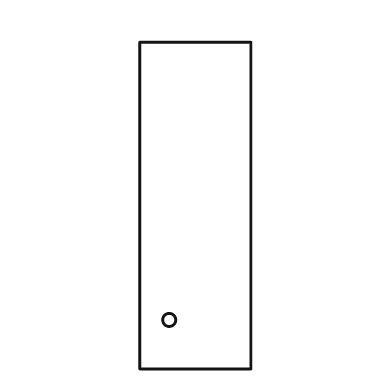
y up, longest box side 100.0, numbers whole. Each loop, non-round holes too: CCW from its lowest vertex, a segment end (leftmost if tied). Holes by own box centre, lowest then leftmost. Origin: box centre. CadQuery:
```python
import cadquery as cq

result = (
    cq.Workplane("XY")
    .moveTo(-17.0, -50.0)
    .lineTo(17.0, -50.0)
    .lineTo(17.0, 50.0)
    .lineTo(-17.0, 50.0)
    .close()
    .moveTo(-8.0, -35.0)
    .circle(2.0)
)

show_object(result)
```